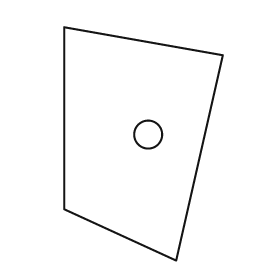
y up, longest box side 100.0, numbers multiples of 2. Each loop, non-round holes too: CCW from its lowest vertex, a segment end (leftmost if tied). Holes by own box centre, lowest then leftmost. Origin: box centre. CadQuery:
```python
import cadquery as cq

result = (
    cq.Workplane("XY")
    .moveTo(14.0, -50.0)
    .lineTo(34.0, 38.0)
    .lineTo(-34.0, 50.0)
    .lineTo(-34.0, -28.0)
    .close()
    .moveTo(2.0, 4.0)
    .circle(6.0)
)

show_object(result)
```